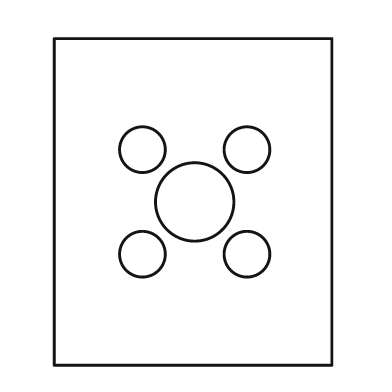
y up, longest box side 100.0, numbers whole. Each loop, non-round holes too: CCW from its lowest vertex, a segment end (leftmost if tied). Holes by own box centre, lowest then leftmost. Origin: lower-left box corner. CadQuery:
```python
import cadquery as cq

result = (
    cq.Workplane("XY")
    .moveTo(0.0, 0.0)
    .lineTo(85.0, 0.0)
    .lineTo(85.0, 100.0)
    .lineTo(0.0, 100.0)
    .close()
    .moveTo(27.0, 34.0)
    .circle(7.0)
    .moveTo(59.0, 34.0)
    .circle(7.0)
    .moveTo(43.0, 50.0)
    .circle(12.0)
    .moveTo(27.0, 66.0)
    .circle(7.0)
    .moveTo(59.0, 66.0)
    .circle(7.0)
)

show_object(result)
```